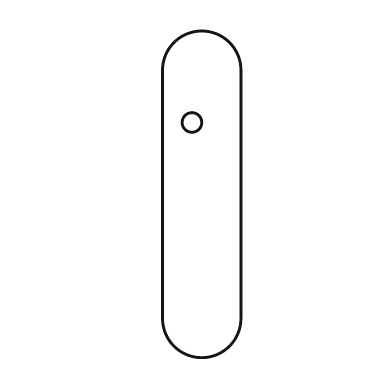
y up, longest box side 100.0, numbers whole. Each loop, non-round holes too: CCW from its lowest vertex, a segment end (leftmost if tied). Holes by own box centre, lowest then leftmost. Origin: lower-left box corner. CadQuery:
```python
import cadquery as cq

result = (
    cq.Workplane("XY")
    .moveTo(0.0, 12.0)
    .threePointArc((12.0, 0.0), (24.0, 12.0))
    .lineTo(24.0, 88.0)
    .threePointArc((12.0, 100.0), (0.0, 88.0))
    .close()
    .moveTo(9.0, 72.0)
    .circle(3.0)
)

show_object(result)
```